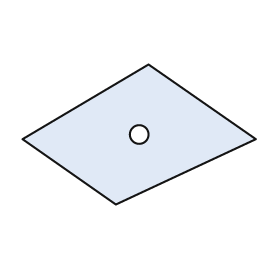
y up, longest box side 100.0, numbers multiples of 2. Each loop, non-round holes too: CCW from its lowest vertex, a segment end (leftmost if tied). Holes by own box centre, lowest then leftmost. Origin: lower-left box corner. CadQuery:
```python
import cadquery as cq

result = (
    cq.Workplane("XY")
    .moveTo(40.0, 0.0)
    .lineTo(100.0, 28.0)
    .lineTo(54.0, 60.0)
    .lineTo(0.0, 28.0)
    .close()
    .moveTo(50.0, 30.0)
    .circle(4.0)
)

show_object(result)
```